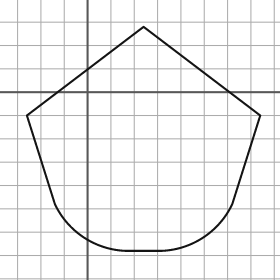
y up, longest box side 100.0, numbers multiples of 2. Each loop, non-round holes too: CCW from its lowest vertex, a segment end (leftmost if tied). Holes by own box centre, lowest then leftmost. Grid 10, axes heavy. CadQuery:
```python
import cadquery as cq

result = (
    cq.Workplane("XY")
    .moveTo(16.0, -68.0)
    .lineTo(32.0, -68.0)
    .threePointArc((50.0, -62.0), (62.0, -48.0))
    .lineTo(74.0, -10.0)
    .lineTo(24.0, 28.0)
    .lineTo(-26.0, -10.0)
    .lineTo(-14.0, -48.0)
    .threePointArc((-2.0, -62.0), (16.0, -68.0))
    .close()
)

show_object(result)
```